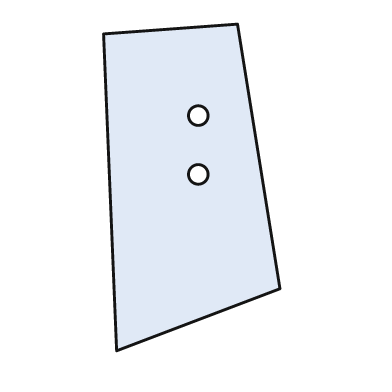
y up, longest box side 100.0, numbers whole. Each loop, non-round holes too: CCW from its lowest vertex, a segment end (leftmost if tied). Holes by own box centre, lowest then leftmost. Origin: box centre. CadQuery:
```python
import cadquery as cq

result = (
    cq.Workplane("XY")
    .moveTo(-23.0, -50.0)
    .lineTo(27.0, -31.0)
    .lineTo(14.0, 50.0)
    .lineTo(-27.0, 47.0)
    .close()
    .moveTo(2.0, 4.0)
    .circle(3.0)
    .moveTo(2.0, 22.0)
    .circle(3.0)
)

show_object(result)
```